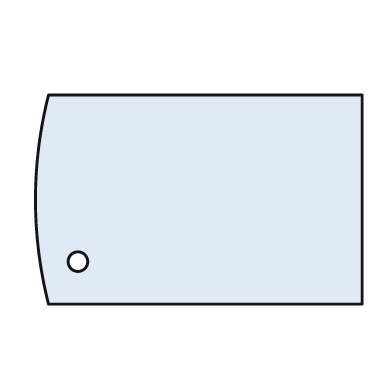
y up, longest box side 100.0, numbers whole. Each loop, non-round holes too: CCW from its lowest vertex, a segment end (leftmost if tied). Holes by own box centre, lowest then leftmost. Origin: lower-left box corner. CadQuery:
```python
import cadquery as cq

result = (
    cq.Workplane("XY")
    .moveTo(4.0, 0.0)
    .lineTo(100.0, 0.0)
    .lineTo(100.0, 64.0)
    .lineTo(4.0, 64.0)
    .threePointArc((0.0, 32.0), (4.0, 0.0))
    .close()
    .moveTo(13.0, 13.0)
    .circle(3.0)
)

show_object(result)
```